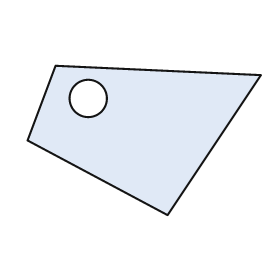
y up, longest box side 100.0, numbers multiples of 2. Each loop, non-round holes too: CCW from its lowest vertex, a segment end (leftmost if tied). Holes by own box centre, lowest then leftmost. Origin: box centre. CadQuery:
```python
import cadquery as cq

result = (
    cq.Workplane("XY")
    .moveTo(10.0, -32.0)
    .lineTo(50.0, 28.0)
    .lineTo(-38.0, 32.0)
    .lineTo(-50.0, 0.0)
    .close()
    .moveTo(-24.0, 18.0)
    .circle(8.0)
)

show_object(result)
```